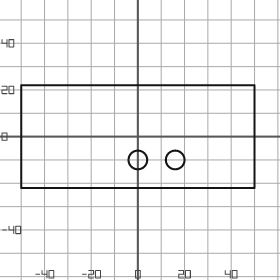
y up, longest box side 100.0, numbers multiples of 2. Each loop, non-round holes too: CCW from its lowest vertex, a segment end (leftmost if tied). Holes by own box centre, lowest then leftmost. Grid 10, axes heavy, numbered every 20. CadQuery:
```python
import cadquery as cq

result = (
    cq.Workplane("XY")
    .moveTo(-50.0, -22.0)
    .lineTo(50.0, -22.0)
    .lineTo(50.0, 22.0)
    .lineTo(-50.0, 22.0)
    .close()
    .moveTo(0.0, -10.0)
    .circle(4.0)
    .moveTo(16.0, -10.0)
    .circle(4.0)
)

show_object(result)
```